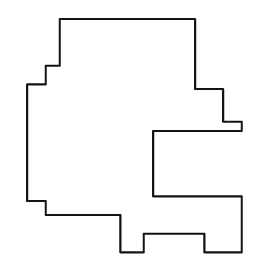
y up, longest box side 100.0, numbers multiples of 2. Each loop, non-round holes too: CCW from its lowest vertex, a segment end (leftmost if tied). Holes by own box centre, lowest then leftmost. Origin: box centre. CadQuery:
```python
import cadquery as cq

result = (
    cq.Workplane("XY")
    .moveTo(-6.0, -50.0)
    .lineTo(4.0, -50.0)
    .lineTo(4.0, -42.0)
    .lineTo(30.0, -42.0)
    .lineTo(30.0, -50.0)
    .lineTo(46.0, -50.0)
    .lineTo(46.0, -26.0)
    .lineTo(8.0, -26.0)
    .lineTo(8.0, 2.0)
    .lineTo(46.0, 2.0)
    .lineTo(46.0, 6.0)
    .lineTo(38.0, 6.0)
    .lineTo(38.0, 20.0)
    .lineTo(26.0, 20.0)
    .lineTo(26.0, 50.0)
    .lineTo(-32.0, 50.0)
    .lineTo(-32.0, 30.0)
    .lineTo(-38.0, 30.0)
    .lineTo(-38.0, 22.0)
    .lineTo(-46.0, 22.0)
    .lineTo(-46.0, -28.0)
    .lineTo(-38.0, -28.0)
    .lineTo(-38.0, -34.0)
    .lineTo(-6.0, -34.0)
    .close()
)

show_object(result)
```